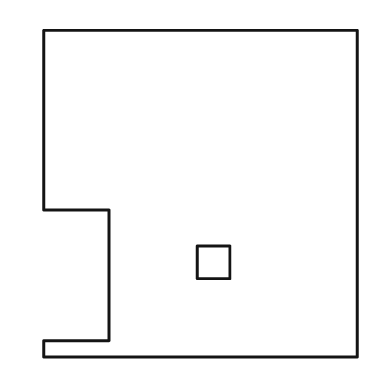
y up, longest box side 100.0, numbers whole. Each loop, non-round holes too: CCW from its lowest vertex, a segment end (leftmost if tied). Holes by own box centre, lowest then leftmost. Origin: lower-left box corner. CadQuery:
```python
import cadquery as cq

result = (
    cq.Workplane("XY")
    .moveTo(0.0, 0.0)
    .lineTo(96.0, 0.0)
    .lineTo(96.0, 100.0)
    .lineTo(0.0, 100.0)
    .lineTo(0.0, 45.0)
    .lineTo(20.0, 45.0)
    .lineTo(20.0, 5.0)
    .lineTo(0.0, 5.0)
    .close()
    .moveTo(47.0, 24.0)
    .lineTo(57.0, 24.0)
    .lineTo(57.0, 34.0)
    .lineTo(47.0, 34.0)
    .close()
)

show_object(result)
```